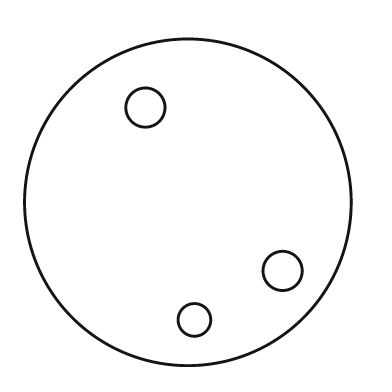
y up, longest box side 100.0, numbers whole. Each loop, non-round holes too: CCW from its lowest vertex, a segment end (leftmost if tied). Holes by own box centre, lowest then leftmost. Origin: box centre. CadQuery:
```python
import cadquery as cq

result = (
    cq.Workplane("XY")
    .moveTo(0.0, 0.0)
    .circle(50.0)
    .moveTo(2.0, -36.0)
    .circle(5.0)
    .moveTo(29.0, -21.0)
    .circle(6.0)
    .moveTo(-13.0, 29.0)
    .circle(6.0)
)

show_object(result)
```